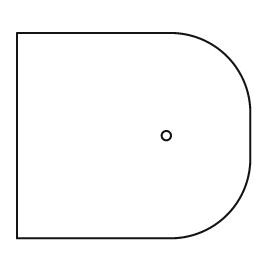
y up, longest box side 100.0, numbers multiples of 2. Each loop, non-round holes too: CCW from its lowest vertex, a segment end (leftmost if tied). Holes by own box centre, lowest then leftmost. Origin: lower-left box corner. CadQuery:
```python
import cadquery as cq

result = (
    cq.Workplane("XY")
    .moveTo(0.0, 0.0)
    .lineTo(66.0, 0.0)
    .threePointArc((90.0, 10.0), (100.0, 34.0))
    .lineTo(100.0, 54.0)
    .threePointArc((90.0, 78.0), (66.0, 88.0))
    .lineTo(0.0, 88.0)
    .close()
    .moveTo(64.0, 44.0)
    .circle(2.0)
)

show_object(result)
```